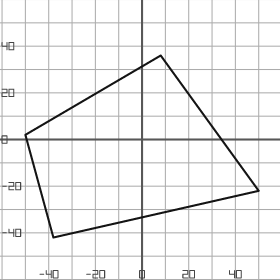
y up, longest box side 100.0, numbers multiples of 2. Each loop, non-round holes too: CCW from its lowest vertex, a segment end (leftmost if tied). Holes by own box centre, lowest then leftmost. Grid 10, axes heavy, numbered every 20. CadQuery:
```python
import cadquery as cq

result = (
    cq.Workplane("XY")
    .moveTo(-38.0, -42.0)
    .lineTo(50.0, -22.0)
    .lineTo(8.0, 36.0)
    .lineTo(-50.0, 2.0)
    .close()
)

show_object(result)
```